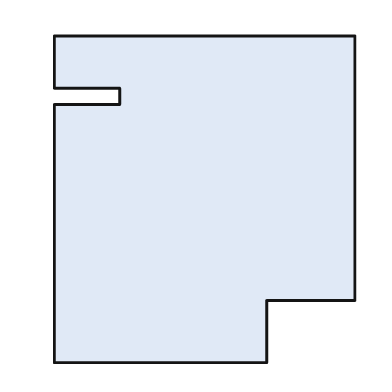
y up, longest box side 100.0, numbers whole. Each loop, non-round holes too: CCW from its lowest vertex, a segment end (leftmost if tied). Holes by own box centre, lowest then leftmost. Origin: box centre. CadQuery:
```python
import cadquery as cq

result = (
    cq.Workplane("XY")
    .moveTo(-46.0, -50.0)
    .lineTo(19.0, -50.0)
    .lineTo(19.0, -31.0)
    .lineTo(46.0, -31.0)
    .lineTo(46.0, 50.0)
    .lineTo(-46.0, 50.0)
    .lineTo(-46.0, 34.0)
    .lineTo(-26.0, 34.0)
    .lineTo(-26.0, 29.0)
    .lineTo(-46.0, 29.0)
    .close()
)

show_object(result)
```